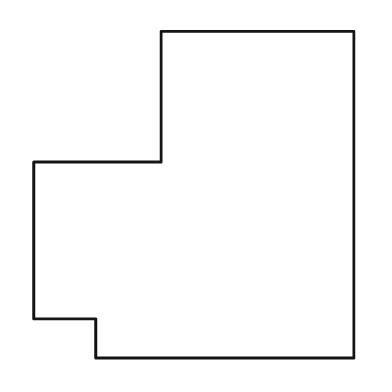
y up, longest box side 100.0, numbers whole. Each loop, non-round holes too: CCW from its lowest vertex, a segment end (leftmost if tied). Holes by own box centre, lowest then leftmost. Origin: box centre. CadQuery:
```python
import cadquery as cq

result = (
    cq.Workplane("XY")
    .moveTo(-30.0, -50.0)
    .lineTo(49.0, -50.0)
    .lineTo(49.0, 50.0)
    .lineTo(-10.0, 50.0)
    .lineTo(-10.0, 10.0)
    .lineTo(-49.0, 10.0)
    .lineTo(-49.0, -38.0)
    .lineTo(-30.0, -38.0)
    .close()
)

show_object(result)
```